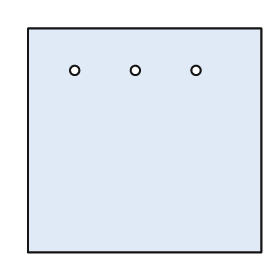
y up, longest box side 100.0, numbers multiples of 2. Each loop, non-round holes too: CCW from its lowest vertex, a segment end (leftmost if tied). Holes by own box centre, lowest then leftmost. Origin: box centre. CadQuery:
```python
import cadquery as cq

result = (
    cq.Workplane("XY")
    .moveTo(-50.0, -48.0)
    .lineTo(50.0, -48.0)
    .lineTo(50.0, 48.0)
    .lineTo(-50.0, 48.0)
    .close()
    .moveTo(-30.0, 30.0)
    .circle(2.0)
    .moveTo(-4.0, 30.0)
    .circle(2.0)
    .moveTo(22.0, 30.0)
    .circle(2.0)
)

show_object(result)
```